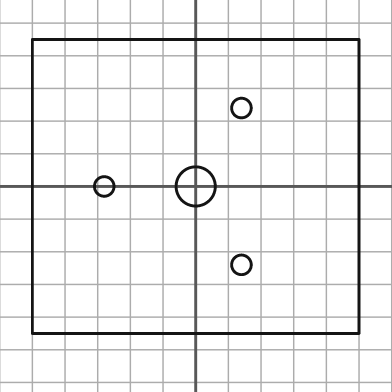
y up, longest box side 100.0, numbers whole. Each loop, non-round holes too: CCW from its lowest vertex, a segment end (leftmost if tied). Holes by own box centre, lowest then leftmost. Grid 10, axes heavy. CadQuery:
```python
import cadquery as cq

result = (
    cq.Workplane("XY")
    .moveTo(-50.0, -45.0)
    .lineTo(50.0, -45.0)
    .lineTo(50.0, 45.0)
    .lineTo(-50.0, 45.0)
    .close()
    .moveTo(14.0, -24.0)
    .circle(3.0)
    .moveTo(-28.0, 0.0)
    .circle(3.0)
    .moveTo(0.0, 0.0)
    .circle(6.0)
    .moveTo(14.0, 24.0)
    .circle(3.0)
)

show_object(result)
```